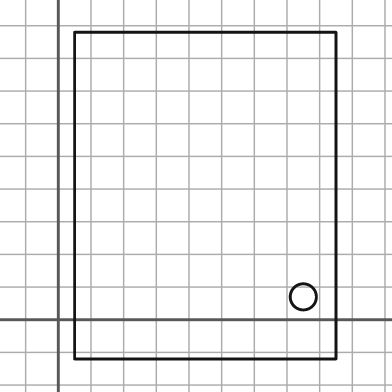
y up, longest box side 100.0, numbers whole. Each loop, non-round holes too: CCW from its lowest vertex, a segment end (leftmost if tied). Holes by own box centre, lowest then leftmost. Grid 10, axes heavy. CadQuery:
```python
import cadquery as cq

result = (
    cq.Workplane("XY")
    .moveTo(5.0, -12.0)
    .lineTo(85.0, -12.0)
    .lineTo(85.0, 88.0)
    .lineTo(5.0, 88.0)
    .close()
    .moveTo(75.0, 7.0)
    .circle(4.0)
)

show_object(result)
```